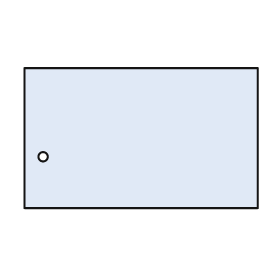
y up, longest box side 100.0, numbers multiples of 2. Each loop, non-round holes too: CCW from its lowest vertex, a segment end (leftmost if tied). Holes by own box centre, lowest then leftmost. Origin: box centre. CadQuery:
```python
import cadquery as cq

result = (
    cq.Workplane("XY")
    .moveTo(-50.0, -30.0)
    .lineTo(50.0, -30.0)
    .lineTo(50.0, 30.0)
    .lineTo(-50.0, 30.0)
    .close()
    .moveTo(-42.0, -8.0)
    .circle(2.0)
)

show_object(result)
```